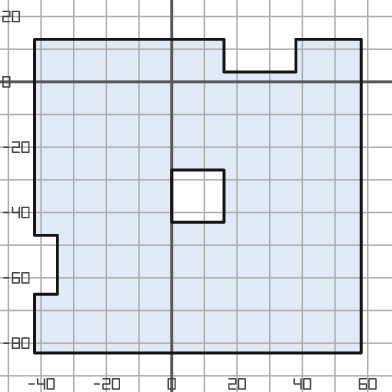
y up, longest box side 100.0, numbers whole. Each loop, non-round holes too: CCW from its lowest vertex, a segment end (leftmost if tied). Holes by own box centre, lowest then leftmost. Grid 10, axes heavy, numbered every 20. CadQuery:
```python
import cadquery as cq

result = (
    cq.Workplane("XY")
    .moveTo(-42.0, -83.0)
    .lineTo(58.0, -83.0)
    .lineTo(58.0, 13.0)
    .lineTo(38.0, 13.0)
    .lineTo(38.0, 3.0)
    .lineTo(16.0, 3.0)
    .lineTo(16.0, 13.0)
    .lineTo(-42.0, 13.0)
    .lineTo(-42.0, -47.0)
    .lineTo(-35.0, -47.0)
    .lineTo(-35.0, -65.0)
    .lineTo(-42.0, -65.0)
    .close()
    .moveTo(0.0, -43.0)
    .lineTo(16.0, -43.0)
    .lineTo(16.0, -27.0)
    .lineTo(0.0, -27.0)
    .close()
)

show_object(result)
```